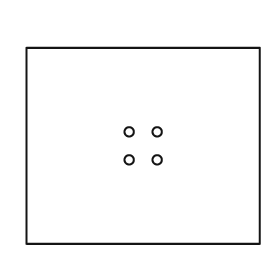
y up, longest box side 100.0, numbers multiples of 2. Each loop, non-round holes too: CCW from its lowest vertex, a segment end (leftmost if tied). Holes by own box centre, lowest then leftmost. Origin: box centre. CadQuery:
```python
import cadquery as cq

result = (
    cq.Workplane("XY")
    .moveTo(-50.0, -42.0)
    .lineTo(50.0, -42.0)
    .lineTo(50.0, 42.0)
    .lineTo(-50.0, 42.0)
    .close()
    .moveTo(-6.0, -6.0)
    .circle(2.0)
    .moveTo(6.0, -6.0)
    .circle(2.0)
    .moveTo(-6.0, 6.0)
    .circle(2.0)
    .moveTo(6.0, 6.0)
    .circle(2.0)
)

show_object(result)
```